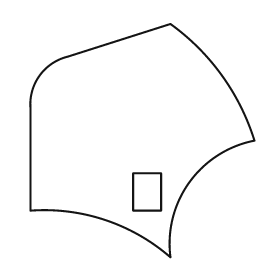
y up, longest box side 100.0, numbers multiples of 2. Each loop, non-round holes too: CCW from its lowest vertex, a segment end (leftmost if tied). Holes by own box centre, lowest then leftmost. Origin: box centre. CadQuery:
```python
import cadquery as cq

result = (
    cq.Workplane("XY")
    .moveTo(12.0, -50.0)
    .threePointArc((20.0, -18.0), (48.0, 0.0))
    .threePointArc((34.0, 28.0), (12.0, 50.0))
    .lineTo(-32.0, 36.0)
    .threePointArc((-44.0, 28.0), (-48.0, 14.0))
    .lineTo(-48.0, -30.0)
    .threePointArc((-16.0, -34.0), (12.0, -50.0))
    .close()
    .moveTo(-4.0, -30.0)
    .lineTo(8.0, -30.0)
    .lineTo(8.0, -14.0)
    .lineTo(-4.0, -14.0)
    .close()
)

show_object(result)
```